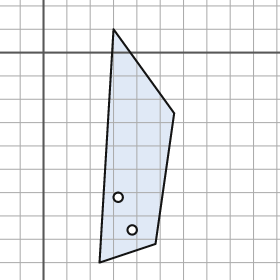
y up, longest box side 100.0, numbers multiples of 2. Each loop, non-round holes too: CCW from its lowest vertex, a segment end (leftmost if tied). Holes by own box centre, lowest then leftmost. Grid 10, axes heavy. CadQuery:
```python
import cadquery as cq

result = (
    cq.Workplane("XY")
    .moveTo(24.0, -90.0)
    .lineTo(48.0, -82.0)
    .lineTo(56.0, -26.0)
    .lineTo(30.0, 10.0)
    .close()
    .moveTo(38.0, -76.0)
    .circle(2.0)
    .moveTo(32.0, -62.0)
    .circle(2.0)
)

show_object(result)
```